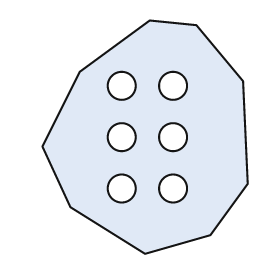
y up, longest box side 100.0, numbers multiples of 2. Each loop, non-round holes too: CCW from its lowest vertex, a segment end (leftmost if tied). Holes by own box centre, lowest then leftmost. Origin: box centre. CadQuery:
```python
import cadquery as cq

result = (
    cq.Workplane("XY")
    .moveTo(0.0, -50.0)
    .lineTo(28.0, -42.0)
    .lineTo(44.0, -20.0)
    .lineTo(42.0, 24.0)
    .lineTo(22.0, 48.0)
    .lineTo(2.0, 50.0)
    .lineTo(-28.0, 28.0)
    .lineTo(-44.0, -4.0)
    .lineTo(-32.0, -30.0)
    .close()
    .moveTo(-10.0, -22.0)
    .circle(6.0)
    .moveTo(12.0, -22.0)
    .circle(6.0)
    .moveTo(-10.0, 0.0)
    .circle(6.0)
    .moveTo(12.0, 0.0)
    .circle(6.0)
    .moveTo(-10.0, 22.0)
    .circle(6.0)
    .moveTo(12.0, 22.0)
    .circle(6.0)
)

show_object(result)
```